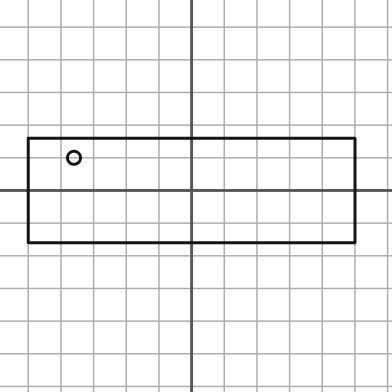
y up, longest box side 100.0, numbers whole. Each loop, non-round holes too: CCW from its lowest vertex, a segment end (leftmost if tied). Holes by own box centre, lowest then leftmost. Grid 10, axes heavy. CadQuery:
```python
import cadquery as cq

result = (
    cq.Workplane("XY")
    .moveTo(-50.0, -16.0)
    .lineTo(50.0, -16.0)
    .lineTo(50.0, 16.0)
    .lineTo(-50.0, 16.0)
    .close()
    .moveTo(-36.0, 10.0)
    .circle(2.0)
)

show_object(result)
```